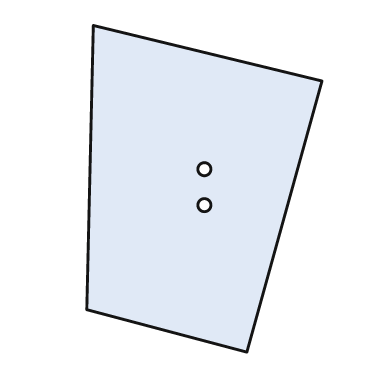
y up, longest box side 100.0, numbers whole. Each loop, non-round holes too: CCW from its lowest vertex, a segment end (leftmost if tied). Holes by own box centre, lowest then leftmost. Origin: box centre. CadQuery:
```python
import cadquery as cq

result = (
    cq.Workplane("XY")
    .moveTo(13.0, -50.0)
    .lineTo(36.0, 33.0)
    .lineTo(-34.0, 50.0)
    .lineTo(-36.0, -37.0)
    .close()
    .moveTo(0.0, -5.0)
    .circle(2.0)
    .moveTo(0.0, 6.0)
    .circle(2.0)
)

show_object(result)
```